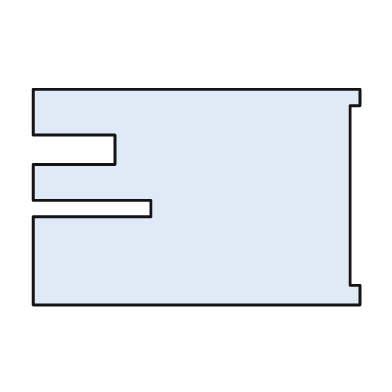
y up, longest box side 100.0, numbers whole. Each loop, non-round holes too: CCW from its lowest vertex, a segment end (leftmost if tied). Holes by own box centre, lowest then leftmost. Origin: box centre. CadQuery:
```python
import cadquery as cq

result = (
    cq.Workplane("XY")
    .moveTo(-50.0, -33.0)
    .lineTo(50.0, -33.0)
    .lineTo(50.0, -27.0)
    .lineTo(47.0, -27.0)
    .lineTo(47.0, 28.0)
    .lineTo(50.0, 28.0)
    .lineTo(50.0, 33.0)
    .lineTo(-50.0, 33.0)
    .lineTo(-50.0, 19.0)
    .lineTo(-25.0, 19.0)
    .lineTo(-25.0, 10.0)
    .lineTo(-50.0, 10.0)
    .lineTo(-50.0, -1.0)
    .lineTo(-14.0, -1.0)
    .lineTo(-14.0, -6.0)
    .lineTo(-50.0, -6.0)
    .close()
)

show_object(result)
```